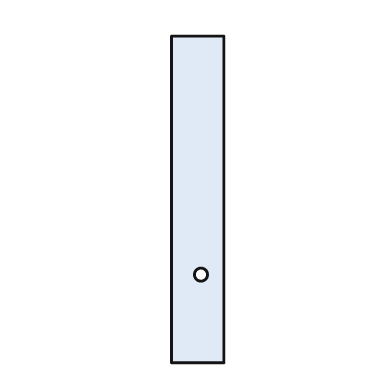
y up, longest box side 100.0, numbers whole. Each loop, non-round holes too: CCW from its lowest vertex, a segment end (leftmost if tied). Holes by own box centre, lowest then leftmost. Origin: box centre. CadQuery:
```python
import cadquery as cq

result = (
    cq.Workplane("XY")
    .moveTo(-8.0, -50.0)
    .lineTo(8.0, -50.0)
    .lineTo(8.0, 50.0)
    .lineTo(-8.0, 50.0)
    .close()
    .moveTo(1.0, -23.0)
    .circle(2.0)
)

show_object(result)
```